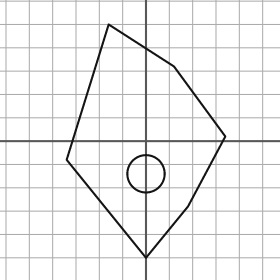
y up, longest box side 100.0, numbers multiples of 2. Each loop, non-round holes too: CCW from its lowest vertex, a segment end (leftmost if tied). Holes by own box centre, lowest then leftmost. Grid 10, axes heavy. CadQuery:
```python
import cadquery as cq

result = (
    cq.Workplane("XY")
    .moveTo(0.0, -50.0)
    .lineTo(18.0, -28.0)
    .lineTo(34.0, 2.0)
    .lineTo(12.0, 32.0)
    .lineTo(-16.0, 50.0)
    .lineTo(-34.0, -8.0)
    .close()
    .moveTo(0.0, -14.0)
    .circle(8.0)
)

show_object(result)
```